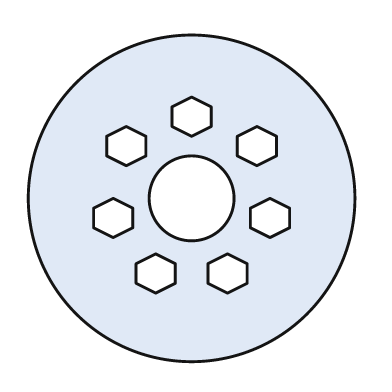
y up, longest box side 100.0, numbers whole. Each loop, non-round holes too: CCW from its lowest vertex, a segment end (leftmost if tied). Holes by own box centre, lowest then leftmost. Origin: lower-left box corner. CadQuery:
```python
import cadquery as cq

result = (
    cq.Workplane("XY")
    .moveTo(50.0, 50.0)
    .circle(50.0)
    .moveTo(39.0, 21.0)
    .lineTo(45.0, 24.0)
    .lineTo(45.0, 30.0)
    .lineTo(39.0, 33.0)
    .lineTo(33.0, 30.0)
    .lineTo(33.0, 24.0)
    .close()
    .moveTo(61.0, 21.0)
    .lineTo(67.0, 24.0)
    .lineTo(67.0, 30.0)
    .lineTo(61.0, 33.0)
    .lineTo(55.0, 30.0)
    .lineTo(55.0, 24.0)
    .close()
    .moveTo(26.0, 38.0)
    .lineTo(32.0, 41.0)
    .lineTo(32.0, 47.0)
    .lineTo(26.0, 50.0)
    .lineTo(20.0, 47.0)
    .lineTo(20.0, 41.0)
    .close()
    .moveTo(74.0, 38.0)
    .lineTo(80.0, 41.0)
    .lineTo(80.0, 47.0)
    .lineTo(74.0, 50.0)
    .lineTo(68.0, 47.0)
    .lineTo(68.0, 41.0)
    .close()
    .moveTo(50.0, 50.0)
    .circle(13.0)
    .moveTo(30.0, 60.0)
    .lineTo(36.0, 63.0)
    .lineTo(36.0, 69.0)
    .lineTo(30.0, 72.0)
    .lineTo(24.0, 69.0)
    .lineTo(24.0, 63.0)
    .close()
    .moveTo(70.0, 60.0)
    .lineTo(76.0, 63.0)
    .lineTo(76.0, 69.0)
    .lineTo(70.0, 72.0)
    .lineTo(64.0, 69.0)
    .lineTo(64.0, 63.0)
    .close()
    .moveTo(50.0, 69.0)
    .lineTo(56.0, 72.0)
    .lineTo(56.0, 78.0)
    .lineTo(50.0, 81.0)
    .lineTo(44.0, 78.0)
    .lineTo(44.0, 72.0)
    .close()
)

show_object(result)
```